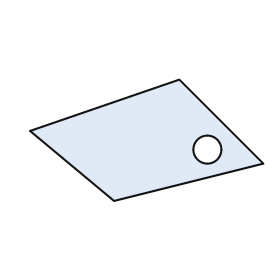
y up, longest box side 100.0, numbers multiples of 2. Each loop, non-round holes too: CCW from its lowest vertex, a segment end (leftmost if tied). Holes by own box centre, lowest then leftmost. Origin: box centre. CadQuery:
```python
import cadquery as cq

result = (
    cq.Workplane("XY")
    .moveTo(-14.0, -26.0)
    .lineTo(50.0, -10.0)
    .lineTo(14.0, 26.0)
    .lineTo(-50.0, 4.0)
    .close()
    .moveTo(26.0, -4.0)
    .circle(6.0)
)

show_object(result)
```